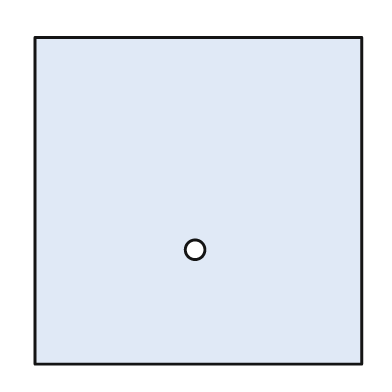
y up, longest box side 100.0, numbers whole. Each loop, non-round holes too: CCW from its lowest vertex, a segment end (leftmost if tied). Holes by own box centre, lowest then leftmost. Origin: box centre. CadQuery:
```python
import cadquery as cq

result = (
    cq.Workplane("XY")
    .moveTo(-50.0, -50.0)
    .lineTo(50.0, -50.0)
    .lineTo(50.0, 50.0)
    .lineTo(-50.0, 50.0)
    .close()
    .moveTo(-1.0, -15.0)
    .circle(3.0)
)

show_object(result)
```